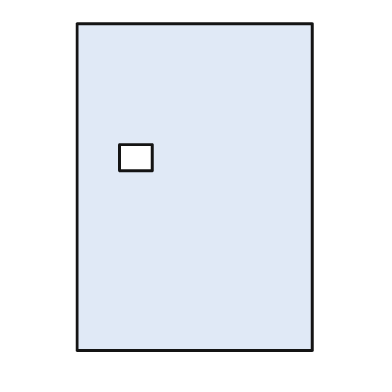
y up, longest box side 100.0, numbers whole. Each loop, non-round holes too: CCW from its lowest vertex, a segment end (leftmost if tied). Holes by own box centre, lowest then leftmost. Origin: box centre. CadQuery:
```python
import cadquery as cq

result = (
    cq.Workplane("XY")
    .moveTo(-36.0, -50.0)
    .lineTo(36.0, -50.0)
    .lineTo(36.0, 50.0)
    .lineTo(-36.0, 50.0)
    .close()
    .moveTo(-23.0, 5.0)
    .lineTo(-13.0, 5.0)
    .lineTo(-13.0, 13.0)
    .lineTo(-23.0, 13.0)
    .close()
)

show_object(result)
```